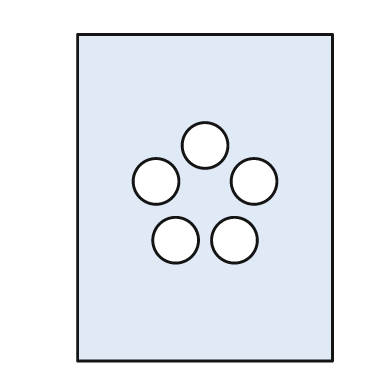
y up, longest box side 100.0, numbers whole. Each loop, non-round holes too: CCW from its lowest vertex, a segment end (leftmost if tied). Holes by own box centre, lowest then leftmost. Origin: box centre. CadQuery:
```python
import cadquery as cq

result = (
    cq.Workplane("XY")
    .moveTo(-39.0, -50.0)
    .lineTo(39.0, -50.0)
    .lineTo(39.0, 50.0)
    .lineTo(-39.0, 50.0)
    .close()
    .moveTo(-9.0, -13.0)
    .circle(7.0)
    .moveTo(9.0, -13.0)
    .circle(7.0)
    .moveTo(-15.0, 5.0)
    .circle(7.0)
    .moveTo(15.0, 5.0)
    .circle(7.0)
    .moveTo(0.0, 16.0)
    .circle(7.0)
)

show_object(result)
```